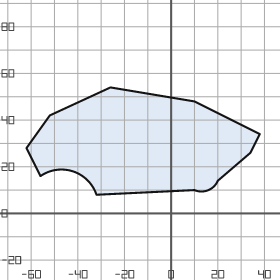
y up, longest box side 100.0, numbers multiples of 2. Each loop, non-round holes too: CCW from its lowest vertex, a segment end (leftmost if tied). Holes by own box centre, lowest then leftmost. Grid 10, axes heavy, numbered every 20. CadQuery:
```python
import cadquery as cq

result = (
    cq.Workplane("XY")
    .moveTo(-32.0, 8.0)
    .lineTo(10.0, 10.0)
    .threePointArc((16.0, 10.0), (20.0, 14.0))
    .lineTo(34.0, 26.0)
    .lineTo(38.0, 34.0)
    .lineTo(10.0, 48.0)
    .lineTo(-26.0, 54.0)
    .lineTo(-52.0, 42.0)
    .lineTo(-62.0, 28.0)
    .lineTo(-56.0, 16.0)
    .threePointArc((-42.0, 18.0), (-32.0, 8.0))
    .close()
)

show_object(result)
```